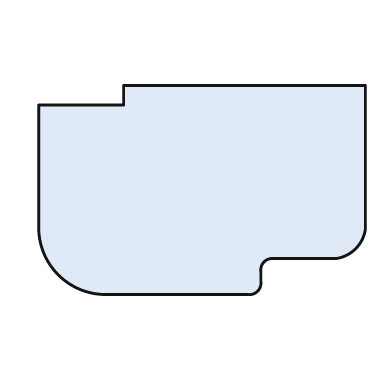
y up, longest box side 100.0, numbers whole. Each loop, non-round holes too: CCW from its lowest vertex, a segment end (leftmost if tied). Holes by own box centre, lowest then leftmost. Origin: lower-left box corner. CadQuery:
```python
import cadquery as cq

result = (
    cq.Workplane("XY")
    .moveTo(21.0, 0.0)
    .lineTo(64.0, 0.0)
    .threePointArc((67.0, 1.0), (68.0, 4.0))
    .lineTo(68.0, 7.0)
    .threePointArc((69.0, 10.0), (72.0, 11.0))
    .lineTo(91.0, 11.0)
    .threePointArc((97.0, 14.0), (100.0, 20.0))
    .lineTo(100.0, 64.0)
    .lineTo(26.0, 64.0)
    .lineTo(26.0, 58.0)
    .lineTo(0.0, 58.0)
    .lineTo(0.0, 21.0)
    .threePointArc((6.0, 6.0), (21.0, 0.0))
    .close()
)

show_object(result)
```